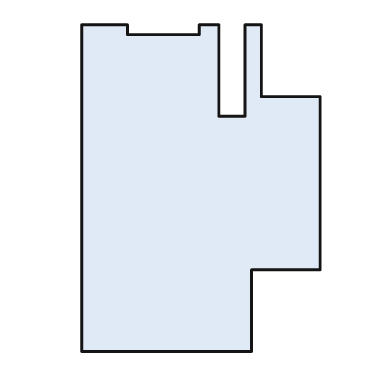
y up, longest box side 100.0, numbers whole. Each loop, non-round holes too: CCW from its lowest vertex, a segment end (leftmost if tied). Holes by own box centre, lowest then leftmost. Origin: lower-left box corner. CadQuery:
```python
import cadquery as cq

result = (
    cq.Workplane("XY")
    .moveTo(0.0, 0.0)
    .lineTo(52.0, 0.0)
    .lineTo(52.0, 25.0)
    .lineTo(73.0, 25.0)
    .lineTo(73.0, 78.0)
    .lineTo(55.0, 78.0)
    .lineTo(55.0, 100.0)
    .lineTo(50.0, 100.0)
    .lineTo(50.0, 72.0)
    .lineTo(42.0, 72.0)
    .lineTo(42.0, 100.0)
    .lineTo(36.0, 100.0)
    .lineTo(36.0, 97.0)
    .lineTo(14.0, 97.0)
    .lineTo(14.0, 100.0)
    .lineTo(0.0, 100.0)
    .close()
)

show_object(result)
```